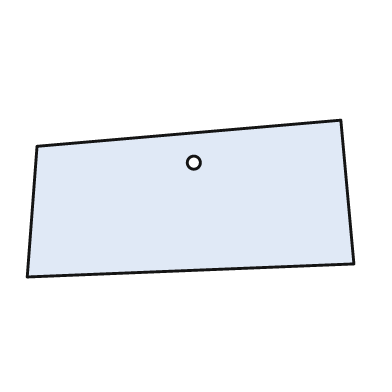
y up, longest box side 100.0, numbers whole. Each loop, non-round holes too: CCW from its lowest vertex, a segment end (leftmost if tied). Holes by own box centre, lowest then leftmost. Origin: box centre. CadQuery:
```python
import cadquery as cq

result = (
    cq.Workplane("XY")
    .moveTo(-50.0, -24.0)
    .lineTo(50.0, -20.0)
    .lineTo(46.0, 24.0)
    .lineTo(-47.0, 16.0)
    .close()
    .moveTo(1.0, 11.0)
    .circle(2.0)
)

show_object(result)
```